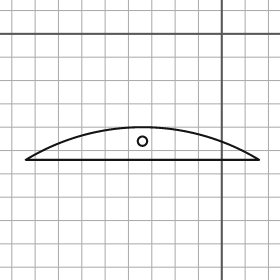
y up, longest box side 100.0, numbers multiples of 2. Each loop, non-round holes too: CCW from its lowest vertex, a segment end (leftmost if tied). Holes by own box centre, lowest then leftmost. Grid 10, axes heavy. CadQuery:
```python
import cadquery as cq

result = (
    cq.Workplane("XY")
    .moveTo(-84.0, -54.0)
    .lineTo(16.0, -54.0)
    .threePointArc((-34.0, -40.0), (-84.0, -54.0))
    .close()
    .moveTo(-34.0, -46.0)
    .circle(2.0)
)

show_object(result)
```